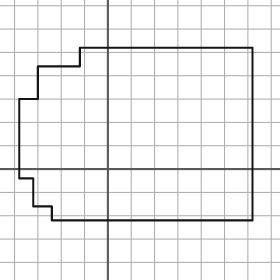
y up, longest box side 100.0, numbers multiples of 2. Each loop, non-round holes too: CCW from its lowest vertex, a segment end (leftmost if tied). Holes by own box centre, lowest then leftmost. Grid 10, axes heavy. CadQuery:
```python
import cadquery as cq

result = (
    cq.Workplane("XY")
    .moveTo(-24.0, -22.0)
    .lineTo(62.0, -22.0)
    .lineTo(62.0, 52.0)
    .lineTo(-12.0, 52.0)
    .lineTo(-12.0, 44.0)
    .lineTo(-30.0, 44.0)
    .lineTo(-30.0, 30.0)
    .lineTo(-38.0, 30.0)
    .lineTo(-38.0, -4.0)
    .lineTo(-32.0, -4.0)
    .lineTo(-32.0, -16.0)
    .lineTo(-24.0, -16.0)
    .close()
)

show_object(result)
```